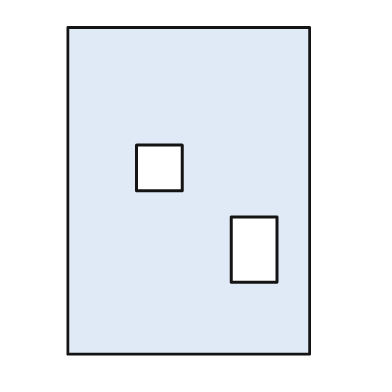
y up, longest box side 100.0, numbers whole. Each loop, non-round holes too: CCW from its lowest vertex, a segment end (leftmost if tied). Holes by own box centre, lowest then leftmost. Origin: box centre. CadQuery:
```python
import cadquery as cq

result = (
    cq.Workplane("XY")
    .moveTo(-37.0, -50.0)
    .lineTo(37.0, -50.0)
    .lineTo(37.0, 50.0)
    .lineTo(-37.0, 50.0)
    .close()
    .moveTo(13.0, -28.0)
    .lineTo(27.0, -28.0)
    .lineTo(27.0, -8.0)
    .lineTo(13.0, -8.0)
    .close()
    .moveTo(-16.0, 0.0)
    .lineTo(-2.0, 0.0)
    .lineTo(-2.0, 14.0)
    .lineTo(-16.0, 14.0)
    .close()
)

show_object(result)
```